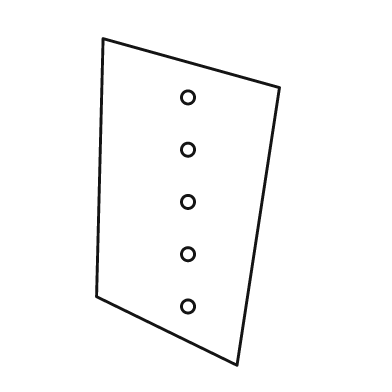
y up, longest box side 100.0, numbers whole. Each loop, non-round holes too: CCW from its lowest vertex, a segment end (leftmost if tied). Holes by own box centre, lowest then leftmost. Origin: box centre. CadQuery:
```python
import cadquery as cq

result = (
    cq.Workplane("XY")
    .moveTo(15.0, -50.0)
    .lineTo(28.0, 35.0)
    .lineTo(-26.0, 50.0)
    .lineTo(-28.0, -29.0)
    .close()
    .moveTo(0.0, -32.0)
    .circle(2.0)
    .moveTo(0.0, -16.0)
    .circle(2.0)
    .moveTo(0.0, 0.0)
    .circle(2.0)
    .moveTo(0.0, 16.0)
    .circle(2.0)
    .moveTo(0.0, 32.0)
    .circle(2.0)
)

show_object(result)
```